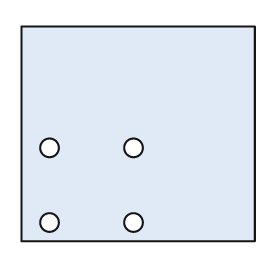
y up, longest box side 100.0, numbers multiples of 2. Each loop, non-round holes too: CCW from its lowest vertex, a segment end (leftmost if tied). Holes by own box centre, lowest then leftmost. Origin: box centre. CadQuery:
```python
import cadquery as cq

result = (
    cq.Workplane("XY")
    .moveTo(-50.0, -46.0)
    .lineTo(50.0, -46.0)
    .lineTo(50.0, 46.0)
    .lineTo(-50.0, 46.0)
    .close()
    .moveTo(-38.0, -38.0)
    .circle(4.0)
    .moveTo(-2.0, -38.0)
    .circle(4.0)
    .moveTo(-38.0, -6.0)
    .circle(4.0)
    .moveTo(-2.0, -6.0)
    .circle(4.0)
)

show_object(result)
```